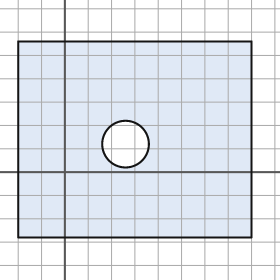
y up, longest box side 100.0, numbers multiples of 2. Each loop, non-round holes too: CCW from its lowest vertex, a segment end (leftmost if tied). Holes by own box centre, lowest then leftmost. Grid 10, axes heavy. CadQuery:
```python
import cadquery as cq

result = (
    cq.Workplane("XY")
    .moveTo(-20.0, -28.0)
    .lineTo(80.0, -28.0)
    .lineTo(80.0, 56.0)
    .lineTo(-20.0, 56.0)
    .close()
    .moveTo(26.0, 12.0)
    .circle(10.0)
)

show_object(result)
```